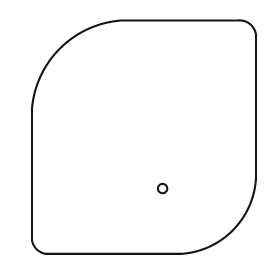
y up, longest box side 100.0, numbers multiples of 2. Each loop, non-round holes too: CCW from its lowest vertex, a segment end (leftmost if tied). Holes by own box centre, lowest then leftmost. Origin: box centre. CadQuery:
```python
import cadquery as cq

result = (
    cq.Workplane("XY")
    .moveTo(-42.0, -50.0)
    .lineTo(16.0, -50.0)
    .threePointArc((38.0, -40.0), (48.0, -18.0))
    .lineTo(48.0, 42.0)
    .threePointArc((46.0, 48.0), (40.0, 50.0))
    .lineTo(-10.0, 50.0)
    .threePointArc((-36.0, 38.0), (-48.0, 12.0))
    .lineTo(-48.0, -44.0)
    .threePointArc((-46.0, -48.0), (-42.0, -50.0))
    .close()
    .moveTo(8.0, -22.0)
    .circle(2.0)
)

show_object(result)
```